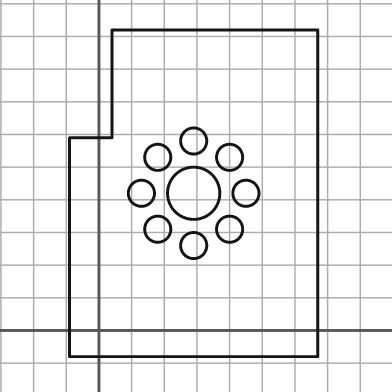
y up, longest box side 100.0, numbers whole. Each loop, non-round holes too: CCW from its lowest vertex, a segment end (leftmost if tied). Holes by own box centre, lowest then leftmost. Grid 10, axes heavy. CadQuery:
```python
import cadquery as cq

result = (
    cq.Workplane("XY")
    .moveTo(-9.0, -8.0)
    .lineTo(67.0, -8.0)
    .lineTo(67.0, 92.0)
    .lineTo(4.0, 92.0)
    .lineTo(4.0, 59.0)
    .lineTo(-9.0, 59.0)
    .close()
    .moveTo(29.0, 26.0)
    .circle(4.0)
    .moveTo(18.0, 31.0)
    .circle(4.0)
    .moveTo(40.0, 31.0)
    .circle(4.0)
    .moveTo(13.0, 42.0)
    .circle(4.0)
    .moveTo(29.0, 42.0)
    .circle(8.0)
    .moveTo(45.0, 42.0)
    .circle(4.0)
    .moveTo(18.0, 53.0)
    .circle(4.0)
    .moveTo(40.0, 53.0)
    .circle(4.0)
    .moveTo(29.0, 58.0)
    .circle(4.0)
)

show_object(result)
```